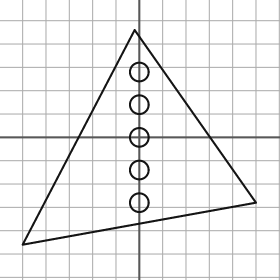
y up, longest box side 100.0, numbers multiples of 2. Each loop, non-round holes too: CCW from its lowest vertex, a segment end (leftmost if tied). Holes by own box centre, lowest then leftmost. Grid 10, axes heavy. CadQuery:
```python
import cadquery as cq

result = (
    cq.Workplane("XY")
    .moveTo(-50.0, -46.0)
    .lineTo(50.0, -28.0)
    .lineTo(-2.0, 46.0)
    .close()
    .moveTo(0.0, -28.0)
    .circle(4.0)
    .moveTo(0.0, -14.0)
    .circle(4.0)
    .moveTo(0.0, 0.0)
    .circle(4.0)
    .moveTo(0.0, 14.0)
    .circle(4.0)
    .moveTo(0.0, 28.0)
    .circle(4.0)
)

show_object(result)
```